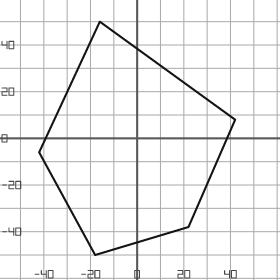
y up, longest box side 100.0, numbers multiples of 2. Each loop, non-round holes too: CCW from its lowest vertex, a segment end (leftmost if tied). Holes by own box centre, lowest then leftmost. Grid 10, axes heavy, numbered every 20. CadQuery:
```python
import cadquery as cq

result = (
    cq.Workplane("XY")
    .moveTo(-18.0, -50.0)
    .lineTo(22.0, -38.0)
    .lineTo(42.0, 8.0)
    .lineTo(-16.0, 50.0)
    .lineTo(-42.0, -6.0)
    .close()
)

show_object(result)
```